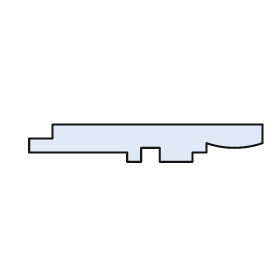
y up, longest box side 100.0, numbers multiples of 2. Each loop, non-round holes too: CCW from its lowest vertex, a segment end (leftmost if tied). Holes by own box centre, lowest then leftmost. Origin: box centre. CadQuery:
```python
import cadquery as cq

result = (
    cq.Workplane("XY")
    .moveTo(-8.0, -8.0)
    .lineTo(-2.0, -8.0)
    .lineTo(-2.0, -2.0)
    .lineTo(6.0, -2.0)
    .lineTo(6.0, -8.0)
    .lineTo(20.0, -8.0)
    .lineTo(20.0, -4.0)
    .lineTo(26.0, -4.0)
    .lineTo(26.0, 0.0)
    .threePointArc((38.0, -2.0), (50.0, 0.0))
    .lineTo(50.0, 8.0)
    .lineTo(-40.0, 8.0)
    .lineTo(-40.0, 2.0)
    .lineTo(-50.0, 2.0)
    .lineTo(-50.0, -4.0)
    .lineTo(-8.0, -4.0)
    .close()
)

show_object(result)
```